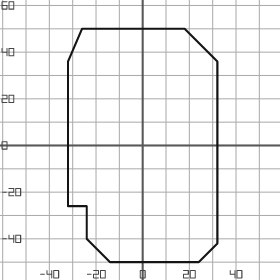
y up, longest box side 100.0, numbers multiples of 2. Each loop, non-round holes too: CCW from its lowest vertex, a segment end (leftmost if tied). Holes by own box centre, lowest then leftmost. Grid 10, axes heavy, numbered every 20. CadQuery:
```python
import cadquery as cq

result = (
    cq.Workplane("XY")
    .moveTo(-14.0, -50.0)
    .lineTo(24.0, -50.0)
    .lineTo(32.0, -42.0)
    .lineTo(32.0, 36.0)
    .lineTo(18.0, 50.0)
    .lineTo(-26.0, 50.0)
    .lineTo(-32.0, 36.0)
    .lineTo(-32.0, -26.0)
    .lineTo(-24.0, -26.0)
    .lineTo(-24.0, -40.0)
    .close()
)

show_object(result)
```